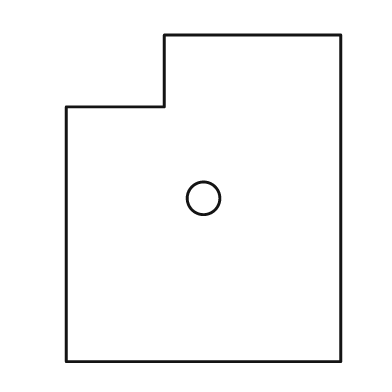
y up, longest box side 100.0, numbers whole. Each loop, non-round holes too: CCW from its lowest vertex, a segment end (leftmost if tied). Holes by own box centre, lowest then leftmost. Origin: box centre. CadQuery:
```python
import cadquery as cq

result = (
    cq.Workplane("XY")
    .moveTo(-42.0, -50.0)
    .lineTo(42.0, -50.0)
    .lineTo(42.0, 50.0)
    .lineTo(-12.0, 50.0)
    .lineTo(-12.0, 28.0)
    .lineTo(-42.0, 28.0)
    .close()
    .moveTo(0.0, 0.0)
    .circle(5.0)
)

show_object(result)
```